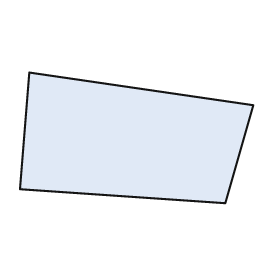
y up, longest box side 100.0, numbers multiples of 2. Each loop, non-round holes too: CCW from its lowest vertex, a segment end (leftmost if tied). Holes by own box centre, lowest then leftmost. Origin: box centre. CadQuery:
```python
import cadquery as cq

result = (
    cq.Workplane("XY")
    .moveTo(38.0, -28.0)
    .lineTo(50.0, 14.0)
    .lineTo(-46.0, 28.0)
    .lineTo(-50.0, -22.0)
    .close()
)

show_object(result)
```